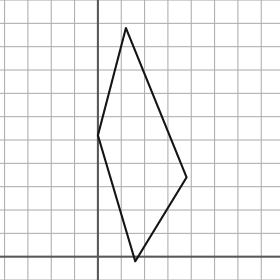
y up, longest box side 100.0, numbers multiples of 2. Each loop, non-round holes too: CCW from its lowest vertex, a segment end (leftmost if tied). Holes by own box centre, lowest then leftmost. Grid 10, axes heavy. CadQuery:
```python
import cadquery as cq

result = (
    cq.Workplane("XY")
    .moveTo(16.0, -2.0)
    .lineTo(38.0, 34.0)
    .lineTo(12.0, 98.0)
    .lineTo(0.0, 52.0)
    .close()
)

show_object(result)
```